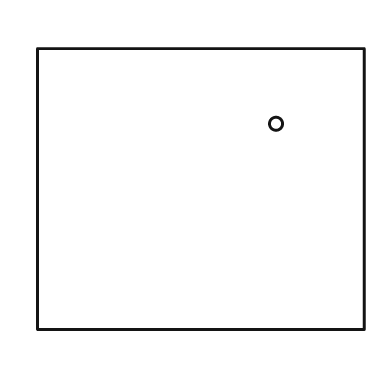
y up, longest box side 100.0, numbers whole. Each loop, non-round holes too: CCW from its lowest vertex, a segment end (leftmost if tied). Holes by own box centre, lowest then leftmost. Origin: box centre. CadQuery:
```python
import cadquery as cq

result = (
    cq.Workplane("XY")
    .moveTo(-50.0, -43.0)
    .lineTo(50.0, -43.0)
    .lineTo(50.0, 43.0)
    .lineTo(-50.0, 43.0)
    .close()
    .moveTo(23.0, 20.0)
    .circle(2.0)
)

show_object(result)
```